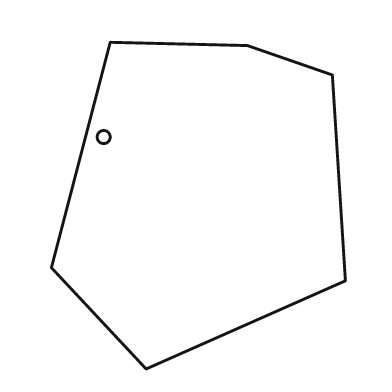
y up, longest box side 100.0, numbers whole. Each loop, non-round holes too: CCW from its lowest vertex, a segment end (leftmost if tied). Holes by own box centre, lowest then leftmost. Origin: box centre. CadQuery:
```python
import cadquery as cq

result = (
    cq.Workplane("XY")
    .moveTo(-16.0, -50.0)
    .lineTo(45.0, -23.0)
    .lineTo(41.0, 40.0)
    .lineTo(15.0, 49.0)
    .lineTo(-27.0, 50.0)
    .lineTo(-45.0, -19.0)
    .close()
    .moveTo(-29.0, 21.0)
    .circle(2.0)
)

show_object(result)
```